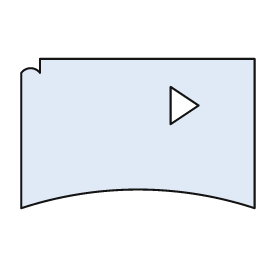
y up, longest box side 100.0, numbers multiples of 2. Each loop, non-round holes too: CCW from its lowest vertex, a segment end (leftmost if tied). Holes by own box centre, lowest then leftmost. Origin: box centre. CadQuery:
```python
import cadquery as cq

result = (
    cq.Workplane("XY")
    .moveTo(-50.0, -32.0)
    .threePointArc((0.0, -24.0), (50.0, -32.0))
    .lineTo(50.0, 32.0)
    .lineTo(-42.0, 32.0)
    .lineTo(-42.0, 26.0)
    .threePointArc((-46.0, 28.0), (-50.0, 26.0))
    .close()
    .moveTo(14.0, 4.0)
    .lineTo(26.0, 12.0)
    .lineTo(14.0, 20.0)
    .close()
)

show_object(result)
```